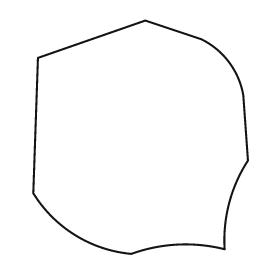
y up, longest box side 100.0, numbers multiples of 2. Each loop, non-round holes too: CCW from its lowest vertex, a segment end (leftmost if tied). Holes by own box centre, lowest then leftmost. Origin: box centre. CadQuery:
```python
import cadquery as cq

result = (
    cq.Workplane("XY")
    .moveTo(-4.0, -50.0)
    .threePointArc((16.0, -46.0), (36.0, -48.0))
    .threePointArc((38.0, -28.0), (46.0, -10.0))
    .lineTo(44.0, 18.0)
    .threePointArc((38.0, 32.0), (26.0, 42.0))
    .lineTo(2.0, 50.0)
    .lineTo(-44.0, 34.0)
    .lineTo(-46.0, -24.0)
    .threePointArc((-28.0, -42.0), (-4.0, -50.0))
    .close()
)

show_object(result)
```